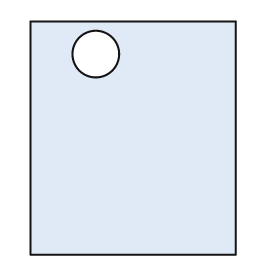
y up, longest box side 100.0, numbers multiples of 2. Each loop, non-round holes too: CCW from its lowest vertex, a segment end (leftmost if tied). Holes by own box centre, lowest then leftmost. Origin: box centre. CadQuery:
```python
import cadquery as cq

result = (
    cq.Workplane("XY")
    .moveTo(-44.0, -50.0)
    .lineTo(44.0, -50.0)
    .lineTo(44.0, 50.0)
    .lineTo(-44.0, 50.0)
    .close()
    .moveTo(-16.0, 36.0)
    .circle(10.0)
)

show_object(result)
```